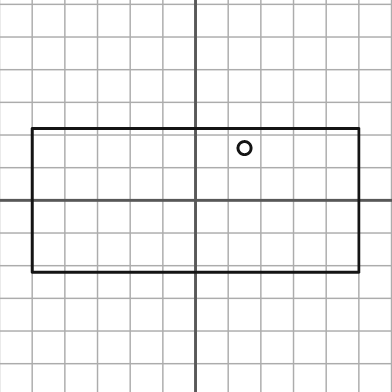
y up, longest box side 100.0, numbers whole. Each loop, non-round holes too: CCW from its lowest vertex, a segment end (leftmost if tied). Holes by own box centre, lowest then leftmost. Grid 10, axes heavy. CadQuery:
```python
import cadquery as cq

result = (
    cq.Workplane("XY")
    .moveTo(-50.0, -22.0)
    .lineTo(50.0, -22.0)
    .lineTo(50.0, 22.0)
    .lineTo(-50.0, 22.0)
    .close()
    .moveTo(15.0, 16.0)
    .circle(2.0)
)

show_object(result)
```